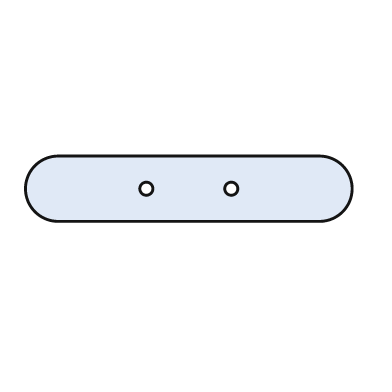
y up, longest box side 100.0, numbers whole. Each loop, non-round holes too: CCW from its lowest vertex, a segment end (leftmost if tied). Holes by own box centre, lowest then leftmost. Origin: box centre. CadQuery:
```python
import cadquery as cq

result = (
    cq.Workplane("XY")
    .moveTo(-40.0, -10.0)
    .lineTo(40.0, -10.0)
    .threePointArc((50.0, 0.0), (40.0, 10.0))
    .lineTo(-40.0, 10.0)
    .threePointArc((-50.0, 0.0), (-40.0, -10.0))
    .close()
    .moveTo(-13.0, 0.0)
    .circle(2.0)
    .moveTo(13.0, 0.0)
    .circle(2.0)
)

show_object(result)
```